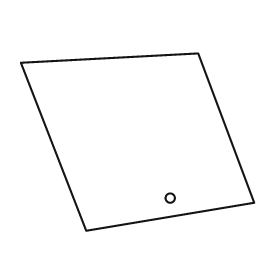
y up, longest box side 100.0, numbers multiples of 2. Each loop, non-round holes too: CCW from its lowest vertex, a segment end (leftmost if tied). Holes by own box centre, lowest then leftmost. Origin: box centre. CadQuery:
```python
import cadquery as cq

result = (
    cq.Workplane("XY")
    .moveTo(-22.0, -38.0)
    .lineTo(50.0, -26.0)
    .lineTo(26.0, 38.0)
    .lineTo(-50.0, 34.0)
    .close()
    .moveTo(14.0, -24.0)
    .circle(2.0)
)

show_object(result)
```